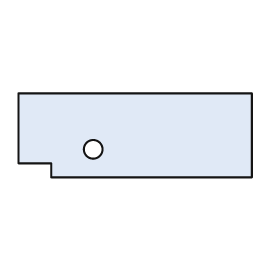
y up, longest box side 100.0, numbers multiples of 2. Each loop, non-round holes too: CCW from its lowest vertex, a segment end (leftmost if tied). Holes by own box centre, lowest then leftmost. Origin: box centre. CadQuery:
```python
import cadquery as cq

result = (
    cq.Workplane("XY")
    .moveTo(-36.0, -18.0)
    .lineTo(50.0, -18.0)
    .lineTo(50.0, 18.0)
    .lineTo(-50.0, 18.0)
    .lineTo(-50.0, -12.0)
    .lineTo(-36.0, -12.0)
    .close()
    .moveTo(-18.0, -6.0)
    .circle(4.0)
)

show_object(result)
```